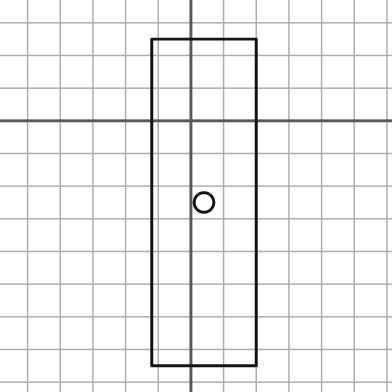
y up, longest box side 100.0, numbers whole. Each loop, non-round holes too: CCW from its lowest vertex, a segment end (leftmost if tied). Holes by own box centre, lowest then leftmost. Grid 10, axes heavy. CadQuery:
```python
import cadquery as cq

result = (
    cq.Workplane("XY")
    .moveTo(-12.0, -75.0)
    .lineTo(20.0, -75.0)
    .lineTo(20.0, 25.0)
    .lineTo(-12.0, 25.0)
    .close()
    .moveTo(4.0, -25.0)
    .circle(3.0)
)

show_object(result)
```